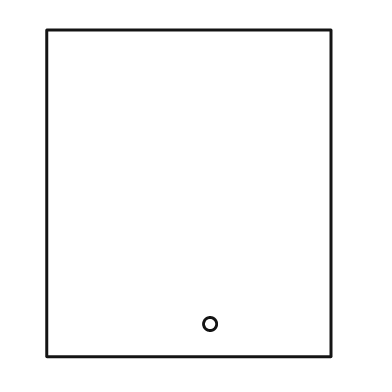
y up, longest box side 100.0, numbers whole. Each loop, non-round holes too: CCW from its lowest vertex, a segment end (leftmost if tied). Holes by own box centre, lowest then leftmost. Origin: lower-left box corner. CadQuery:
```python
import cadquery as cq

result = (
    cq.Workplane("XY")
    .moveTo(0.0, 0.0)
    .lineTo(87.0, 0.0)
    .lineTo(87.0, 100.0)
    .lineTo(0.0, 100.0)
    .close()
    .moveTo(50.0, 10.0)
    .circle(2.0)
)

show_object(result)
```